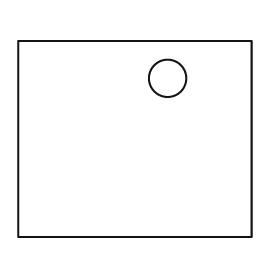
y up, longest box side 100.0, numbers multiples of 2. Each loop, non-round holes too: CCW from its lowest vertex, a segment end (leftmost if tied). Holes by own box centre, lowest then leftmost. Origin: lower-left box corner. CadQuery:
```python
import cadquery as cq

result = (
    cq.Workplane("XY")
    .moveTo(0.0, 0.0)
    .lineTo(100.0, 0.0)
    .lineTo(100.0, 84.0)
    .lineTo(0.0, 84.0)
    .close()
    .moveTo(64.0, 68.0)
    .circle(8.0)
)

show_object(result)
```